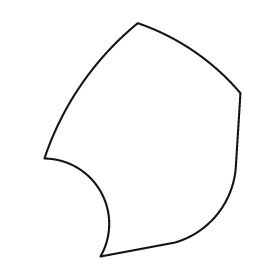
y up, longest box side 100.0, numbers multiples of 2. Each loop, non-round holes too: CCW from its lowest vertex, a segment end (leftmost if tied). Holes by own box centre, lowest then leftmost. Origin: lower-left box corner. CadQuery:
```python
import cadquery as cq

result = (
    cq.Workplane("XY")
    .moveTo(24.0, 0.0)
    .lineTo(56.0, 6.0)
    .threePointArc((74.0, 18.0), (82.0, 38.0))
    .lineTo(84.0, 70.0)
    .threePointArc((64.0, 88.0), (40.0, 100.0))
    .threePointArc((16.0, 74.0), (0.0, 42.0))
    .threePointArc((24.0, 28.0), (24.0, 0.0))
    .close()
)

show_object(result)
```